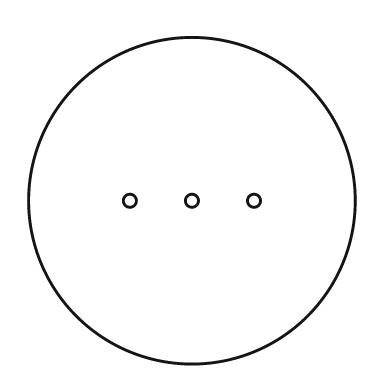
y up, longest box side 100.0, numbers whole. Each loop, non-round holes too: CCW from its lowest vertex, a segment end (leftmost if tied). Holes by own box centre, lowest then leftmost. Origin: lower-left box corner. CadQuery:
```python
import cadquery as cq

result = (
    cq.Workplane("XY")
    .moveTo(50.0, 50.0)
    .circle(50.0)
    .moveTo(31.0, 50.0)
    .circle(2.0)
    .moveTo(50.0, 50.0)
    .circle(2.0)
    .moveTo(69.0, 50.0)
    .circle(2.0)
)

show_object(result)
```